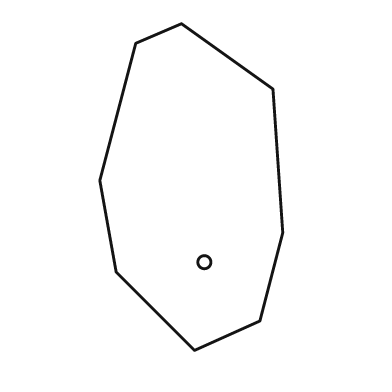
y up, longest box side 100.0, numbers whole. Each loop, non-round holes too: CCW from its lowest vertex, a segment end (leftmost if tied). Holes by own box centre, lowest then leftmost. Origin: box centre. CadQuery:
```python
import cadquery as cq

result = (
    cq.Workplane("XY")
    .moveTo(1.0, -50.0)
    .lineTo(21.0, -41.0)
    .lineTo(28.0, -14.0)
    .lineTo(25.0, 30.0)
    .lineTo(-3.0, 50.0)
    .lineTo(-17.0, 44.0)
    .lineTo(-28.0, 2.0)
    .lineTo(-23.0, -26.0)
    .close()
    .moveTo(4.0, -23.0)
    .circle(2.0)
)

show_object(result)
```